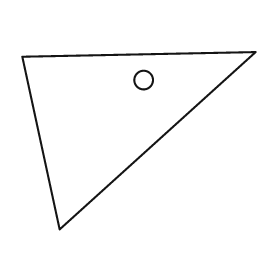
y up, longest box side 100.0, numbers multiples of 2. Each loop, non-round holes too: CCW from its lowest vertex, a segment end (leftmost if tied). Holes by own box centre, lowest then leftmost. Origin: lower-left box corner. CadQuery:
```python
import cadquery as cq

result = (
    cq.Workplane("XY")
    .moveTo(16.0, 0.0)
    .lineTo(100.0, 76.0)
    .lineTo(0.0, 74.0)
    .close()
    .moveTo(52.0, 64.0)
    .circle(4.0)
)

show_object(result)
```